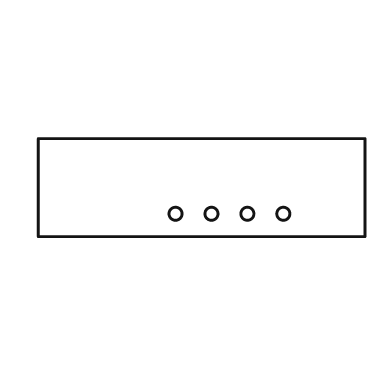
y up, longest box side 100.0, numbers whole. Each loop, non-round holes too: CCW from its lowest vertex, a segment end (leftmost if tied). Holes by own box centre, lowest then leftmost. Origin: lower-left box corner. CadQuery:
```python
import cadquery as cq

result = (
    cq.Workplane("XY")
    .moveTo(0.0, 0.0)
    .lineTo(100.0, 0.0)
    .lineTo(100.0, 30.0)
    .lineTo(0.0, 30.0)
    .close()
    .moveTo(42.0, 7.0)
    .circle(2.0)
    .moveTo(53.0, 7.0)
    .circle(2.0)
    .moveTo(64.0, 7.0)
    .circle(2.0)
    .moveTo(75.0, 7.0)
    .circle(2.0)
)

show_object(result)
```